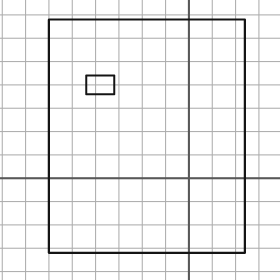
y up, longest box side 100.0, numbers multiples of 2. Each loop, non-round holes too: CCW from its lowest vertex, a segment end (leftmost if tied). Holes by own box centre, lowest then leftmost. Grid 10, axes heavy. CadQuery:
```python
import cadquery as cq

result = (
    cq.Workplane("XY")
    .moveTo(-60.0, -32.0)
    .lineTo(24.0, -32.0)
    .lineTo(24.0, 68.0)
    .lineTo(-60.0, 68.0)
    .close()
    .moveTo(-44.0, 36.0)
    .lineTo(-32.0, 36.0)
    .lineTo(-32.0, 44.0)
    .lineTo(-44.0, 44.0)
    .close()
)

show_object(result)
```